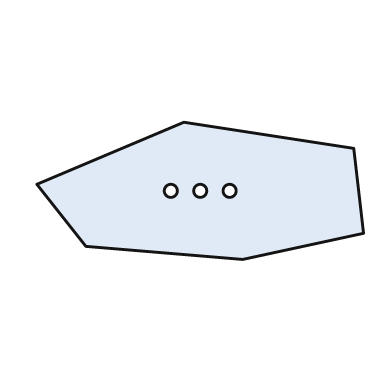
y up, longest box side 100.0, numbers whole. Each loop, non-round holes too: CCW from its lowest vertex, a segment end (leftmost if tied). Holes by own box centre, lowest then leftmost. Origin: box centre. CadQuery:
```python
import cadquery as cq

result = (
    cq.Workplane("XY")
    .moveTo(13.0, -21.0)
    .lineTo(50.0, -13.0)
    .lineTo(47.0, 13.0)
    .lineTo(-5.0, 21.0)
    .lineTo(-50.0, 2.0)
    .lineTo(-35.0, -17.0)
    .close()
    .moveTo(-9.0, 0.0)
    .circle(2.0)
    .moveTo(0.0, 0.0)
    .circle(2.0)
    .moveTo(9.0, 0.0)
    .circle(2.0)
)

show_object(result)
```